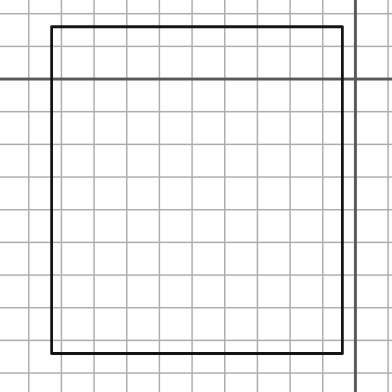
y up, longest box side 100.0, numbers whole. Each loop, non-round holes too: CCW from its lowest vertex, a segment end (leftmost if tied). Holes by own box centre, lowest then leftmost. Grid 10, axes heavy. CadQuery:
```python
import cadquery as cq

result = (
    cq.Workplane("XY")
    .moveTo(-93.0, -84.0)
    .lineTo(-4.0, -84.0)
    .lineTo(-4.0, 16.0)
    .lineTo(-93.0, 16.0)
    .close()
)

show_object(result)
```